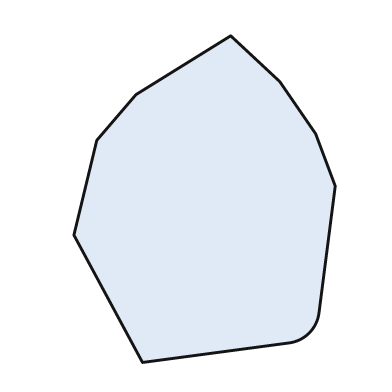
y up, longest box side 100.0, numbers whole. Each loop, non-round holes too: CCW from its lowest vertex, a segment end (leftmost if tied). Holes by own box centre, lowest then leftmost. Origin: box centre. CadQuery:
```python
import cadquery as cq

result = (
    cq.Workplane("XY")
    .moveTo(-19.0, -50.0)
    .lineTo(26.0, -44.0)
    .threePointArc((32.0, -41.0), (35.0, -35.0))
    .lineTo(40.0, 4.0)
    .lineTo(34.0, 20.0)
    .lineTo(23.0, 36.0)
    .lineTo(8.0, 50.0)
    .lineTo(-21.0, 32.0)
    .lineTo(-33.0, 18.0)
    .lineTo(-40.0, -11.0)
    .close()
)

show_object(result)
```